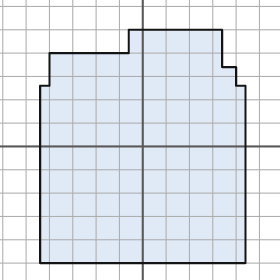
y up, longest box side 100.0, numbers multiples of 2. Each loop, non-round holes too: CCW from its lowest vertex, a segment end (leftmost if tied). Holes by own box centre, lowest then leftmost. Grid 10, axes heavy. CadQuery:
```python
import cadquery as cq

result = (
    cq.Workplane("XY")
    .moveTo(-44.0, -50.0)
    .lineTo(44.0, -50.0)
    .lineTo(44.0, 26.0)
    .lineTo(40.0, 26.0)
    .lineTo(40.0, 34.0)
    .lineTo(34.0, 34.0)
    .lineTo(34.0, 50.0)
    .lineTo(-6.0, 50.0)
    .lineTo(-6.0, 40.0)
    .lineTo(-40.0, 40.0)
    .lineTo(-40.0, 26.0)
    .lineTo(-44.0, 26.0)
    .close()
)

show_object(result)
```